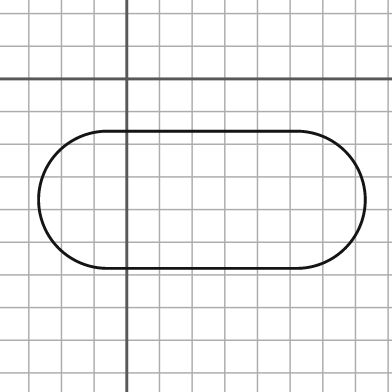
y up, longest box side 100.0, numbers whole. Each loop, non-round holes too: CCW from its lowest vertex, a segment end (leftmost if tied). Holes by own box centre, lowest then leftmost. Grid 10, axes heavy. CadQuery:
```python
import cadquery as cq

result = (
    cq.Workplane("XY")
    .moveTo(-6.0, -58.0)
    .lineTo(52.0, -58.0)
    .threePointArc((73.0, -37.0), (52.0, -16.0))
    .lineTo(-6.0, -16.0)
    .threePointArc((-27.0, -37.0), (-6.0, -58.0))
    .close()
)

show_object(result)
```